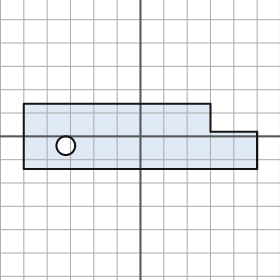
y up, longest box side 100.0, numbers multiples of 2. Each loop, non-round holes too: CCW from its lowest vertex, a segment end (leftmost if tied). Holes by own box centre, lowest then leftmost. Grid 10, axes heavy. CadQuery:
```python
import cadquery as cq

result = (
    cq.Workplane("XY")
    .moveTo(-50.0, -14.0)
    .lineTo(50.0, -14.0)
    .lineTo(50.0, 2.0)
    .lineTo(30.0, 2.0)
    .lineTo(30.0, 14.0)
    .lineTo(-50.0, 14.0)
    .close()
    .moveTo(-32.0, -4.0)
    .circle(4.0)
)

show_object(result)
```